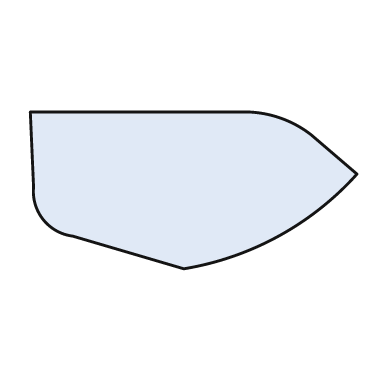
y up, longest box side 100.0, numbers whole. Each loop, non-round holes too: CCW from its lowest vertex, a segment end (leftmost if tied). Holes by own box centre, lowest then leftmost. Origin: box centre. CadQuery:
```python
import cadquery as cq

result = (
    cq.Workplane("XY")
    .moveTo(-3.0, -24.0)
    .threePointArc((26.0, -14.0), (50.0, 5.0))
    .lineTo(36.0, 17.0)
    .threePointArc((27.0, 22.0), (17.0, 24.0))
    .lineTo(-50.0, 24.0)
    .lineTo(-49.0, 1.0)
    .threePointArc((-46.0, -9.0), (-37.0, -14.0))
    .close()
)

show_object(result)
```